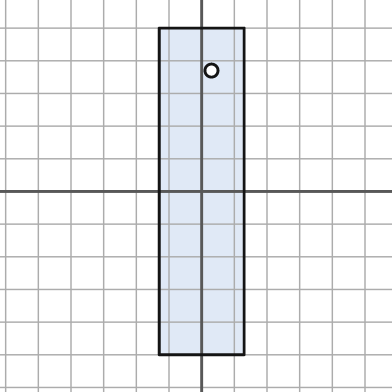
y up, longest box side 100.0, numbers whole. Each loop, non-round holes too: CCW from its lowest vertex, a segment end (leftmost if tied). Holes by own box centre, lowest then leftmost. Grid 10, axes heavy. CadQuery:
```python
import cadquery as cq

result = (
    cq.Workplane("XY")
    .moveTo(-13.0, -50.0)
    .lineTo(13.0, -50.0)
    .lineTo(13.0, 50.0)
    .lineTo(-13.0, 50.0)
    .close()
    .moveTo(3.0, 37.0)
    .circle(2.0)
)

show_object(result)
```